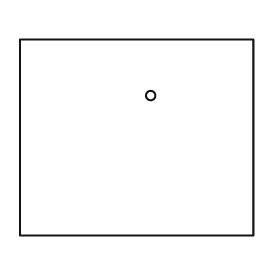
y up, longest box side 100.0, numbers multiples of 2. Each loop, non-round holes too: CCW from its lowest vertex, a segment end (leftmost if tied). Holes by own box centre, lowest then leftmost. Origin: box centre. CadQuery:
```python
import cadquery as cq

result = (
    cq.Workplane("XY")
    .moveTo(-50.0, -42.0)
    .lineTo(50.0, -42.0)
    .lineTo(50.0, 42.0)
    .lineTo(-50.0, 42.0)
    .close()
    .moveTo(6.0, 18.0)
    .circle(2.0)
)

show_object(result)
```